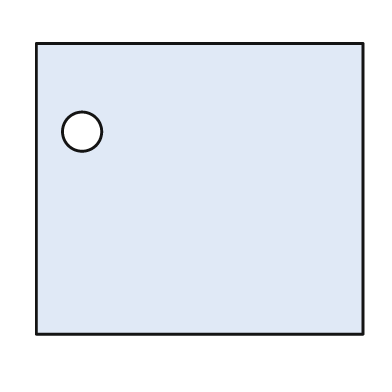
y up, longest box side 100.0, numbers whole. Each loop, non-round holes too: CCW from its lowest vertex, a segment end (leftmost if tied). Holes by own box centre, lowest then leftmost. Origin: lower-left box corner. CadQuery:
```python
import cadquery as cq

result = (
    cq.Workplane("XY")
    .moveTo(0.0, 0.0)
    .lineTo(100.0, 0.0)
    .lineTo(100.0, 89.0)
    .lineTo(0.0, 89.0)
    .close()
    .moveTo(14.0, 62.0)
    .circle(6.0)
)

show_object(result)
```